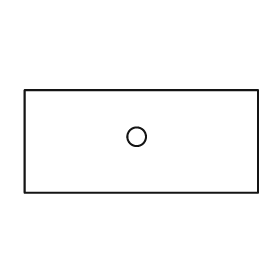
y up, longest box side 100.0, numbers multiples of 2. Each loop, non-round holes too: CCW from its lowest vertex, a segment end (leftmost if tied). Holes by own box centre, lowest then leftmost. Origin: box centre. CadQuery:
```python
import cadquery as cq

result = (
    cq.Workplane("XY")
    .moveTo(-50.0, -22.0)
    .lineTo(50.0, -22.0)
    .lineTo(50.0, 22.0)
    .lineTo(-50.0, 22.0)
    .close()
    .moveTo(-2.0, 2.0)
    .circle(4.0)
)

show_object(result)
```